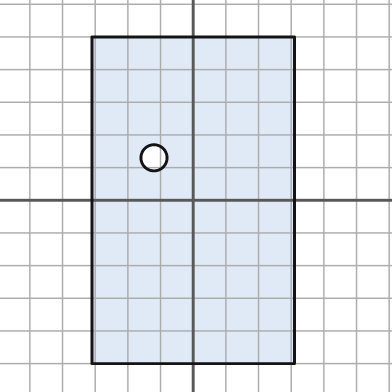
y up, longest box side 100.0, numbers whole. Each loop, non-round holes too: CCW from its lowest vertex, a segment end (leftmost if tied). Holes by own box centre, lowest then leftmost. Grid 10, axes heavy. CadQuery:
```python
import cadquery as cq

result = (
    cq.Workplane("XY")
    .moveTo(-31.0, -50.0)
    .lineTo(31.0, -50.0)
    .lineTo(31.0, 50.0)
    .lineTo(-31.0, 50.0)
    .close()
    .moveTo(-12.0, 13.0)
    .circle(4.0)
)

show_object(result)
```